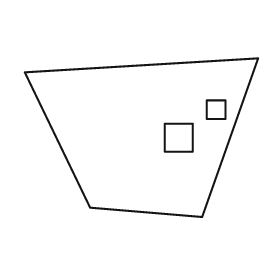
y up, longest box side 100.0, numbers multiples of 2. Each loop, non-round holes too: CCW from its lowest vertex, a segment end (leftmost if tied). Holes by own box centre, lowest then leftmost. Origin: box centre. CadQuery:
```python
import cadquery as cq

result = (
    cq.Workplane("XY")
    .moveTo(26.0, -34.0)
    .lineTo(50.0, 34.0)
    .lineTo(-50.0, 28.0)
    .lineTo(-22.0, -30.0)
    .close()
    .moveTo(10.0, -6.0)
    .lineTo(22.0, -6.0)
    .lineTo(22.0, 6.0)
    .lineTo(10.0, 6.0)
    .close()
    .moveTo(28.0, 8.0)
    .lineTo(36.0, 8.0)
    .lineTo(36.0, 16.0)
    .lineTo(28.0, 16.0)
    .close()
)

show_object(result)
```